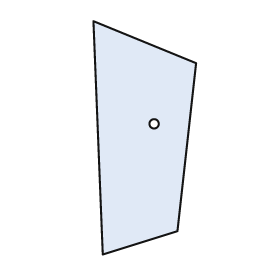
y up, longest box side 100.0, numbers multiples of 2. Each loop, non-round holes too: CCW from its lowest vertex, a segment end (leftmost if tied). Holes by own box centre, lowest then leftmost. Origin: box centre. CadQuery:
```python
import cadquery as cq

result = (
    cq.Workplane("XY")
    .moveTo(-18.0, -50.0)
    .lineTo(14.0, -40.0)
    .lineTo(22.0, 32.0)
    .lineTo(-22.0, 50.0)
    .close()
    .moveTo(4.0, 6.0)
    .circle(2.0)
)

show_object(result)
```